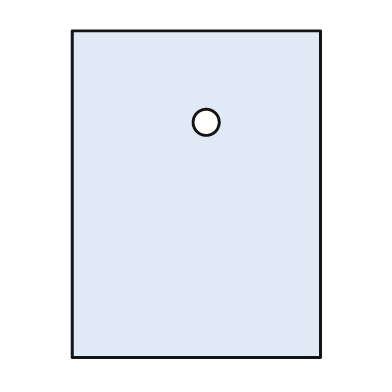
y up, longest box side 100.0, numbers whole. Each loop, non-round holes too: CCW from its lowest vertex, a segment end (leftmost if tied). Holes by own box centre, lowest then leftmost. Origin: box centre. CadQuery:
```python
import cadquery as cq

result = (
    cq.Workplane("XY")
    .moveTo(-38.0, -50.0)
    .lineTo(38.0, -50.0)
    .lineTo(38.0, 50.0)
    .lineTo(-38.0, 50.0)
    .close()
    .moveTo(3.0, 22.0)
    .circle(4.0)
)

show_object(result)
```